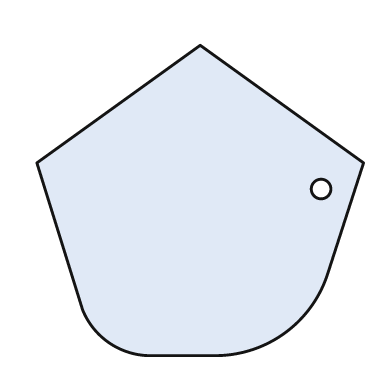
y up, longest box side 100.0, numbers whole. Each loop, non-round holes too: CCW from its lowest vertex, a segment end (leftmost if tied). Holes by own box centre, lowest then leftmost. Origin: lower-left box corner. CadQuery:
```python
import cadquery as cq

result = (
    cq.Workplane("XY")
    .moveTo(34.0, 0.0)
    .lineTo(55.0, 0.0)
    .threePointArc((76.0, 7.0), (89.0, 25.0))
    .lineTo(100.0, 59.0)
    .lineTo(50.0, 95.0)
    .lineTo(0.0, 59.0)
    .lineTo(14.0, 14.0)
    .threePointArc((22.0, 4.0), (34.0, 0.0))
    .close()
    .moveTo(87.0, 51.0)
    .circle(3.0)
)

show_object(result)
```